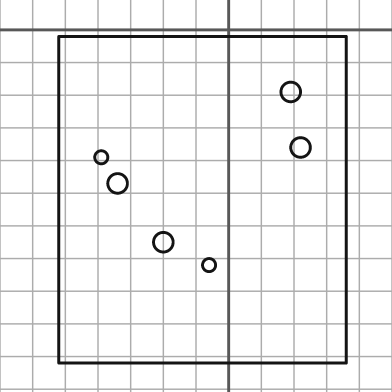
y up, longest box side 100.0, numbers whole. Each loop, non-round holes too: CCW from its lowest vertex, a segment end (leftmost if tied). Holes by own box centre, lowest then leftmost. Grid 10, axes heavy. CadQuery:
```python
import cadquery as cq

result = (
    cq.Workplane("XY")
    .moveTo(-52.0, -102.0)
    .lineTo(36.0, -102.0)
    .lineTo(36.0, -2.0)
    .lineTo(-52.0, -2.0)
    .close()
    .moveTo(-6.0, -72.0)
    .circle(2.0)
    .moveTo(-20.0, -65.0)
    .circle(3.0)
    .moveTo(-34.0, -47.0)
    .circle(3.0)
    .moveTo(-39.0, -39.0)
    .circle(2.0)
    .moveTo(22.0, -36.0)
    .circle(3.0)
    .moveTo(19.0, -19.0)
    .circle(3.0)
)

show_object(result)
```